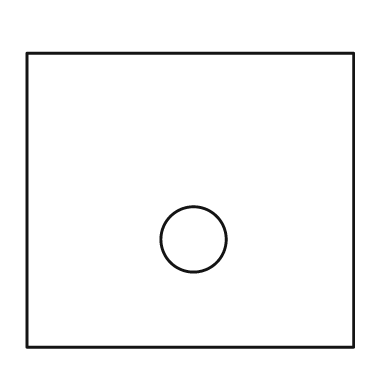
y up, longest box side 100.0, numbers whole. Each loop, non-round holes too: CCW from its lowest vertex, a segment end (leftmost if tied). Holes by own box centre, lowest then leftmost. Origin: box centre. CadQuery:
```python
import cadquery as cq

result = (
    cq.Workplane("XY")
    .moveTo(-50.0, -45.0)
    .lineTo(50.0, -45.0)
    .lineTo(50.0, 45.0)
    .lineTo(-50.0, 45.0)
    .close()
    .moveTo(1.0, -12.0)
    .circle(10.0)
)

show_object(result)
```